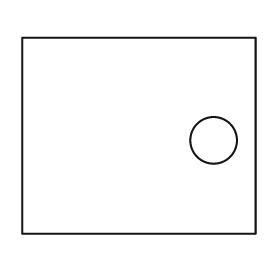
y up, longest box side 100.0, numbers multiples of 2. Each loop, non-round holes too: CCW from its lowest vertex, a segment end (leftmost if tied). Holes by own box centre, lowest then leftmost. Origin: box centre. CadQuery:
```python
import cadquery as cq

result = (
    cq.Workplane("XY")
    .moveTo(-50.0, -42.0)
    .lineTo(50.0, -42.0)
    .lineTo(50.0, 42.0)
    .lineTo(-50.0, 42.0)
    .close()
    .moveTo(32.0, -2.0)
    .circle(10.0)
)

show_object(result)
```